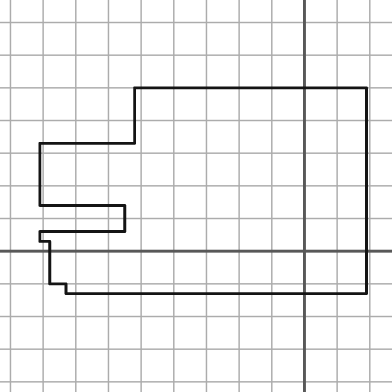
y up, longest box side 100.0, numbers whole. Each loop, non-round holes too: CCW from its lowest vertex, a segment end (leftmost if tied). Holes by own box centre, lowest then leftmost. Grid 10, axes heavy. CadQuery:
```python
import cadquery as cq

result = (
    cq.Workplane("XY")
    .moveTo(-73.0, -13.0)
    .lineTo(19.0, -13.0)
    .lineTo(19.0, 50.0)
    .lineTo(-52.0, 50.0)
    .lineTo(-52.0, 33.0)
    .lineTo(-81.0, 33.0)
    .lineTo(-81.0, 14.0)
    .lineTo(-55.0, 14.0)
    .lineTo(-55.0, 6.0)
    .lineTo(-81.0, 6.0)
    .lineTo(-81.0, 3.0)
    .lineTo(-78.0, 3.0)
    .lineTo(-78.0, -10.0)
    .lineTo(-73.0, -10.0)
    .close()
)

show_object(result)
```